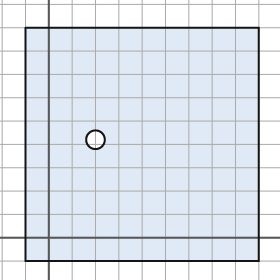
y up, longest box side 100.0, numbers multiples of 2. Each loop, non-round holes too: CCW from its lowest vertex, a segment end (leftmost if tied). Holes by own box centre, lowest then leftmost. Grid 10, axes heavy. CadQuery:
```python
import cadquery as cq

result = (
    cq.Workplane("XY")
    .moveTo(-10.0, -10.0)
    .lineTo(90.0, -10.0)
    .lineTo(90.0, 90.0)
    .lineTo(-10.0, 90.0)
    .close()
    .moveTo(20.0, 42.0)
    .circle(4.0)
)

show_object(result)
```